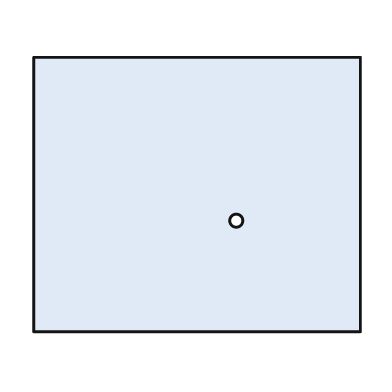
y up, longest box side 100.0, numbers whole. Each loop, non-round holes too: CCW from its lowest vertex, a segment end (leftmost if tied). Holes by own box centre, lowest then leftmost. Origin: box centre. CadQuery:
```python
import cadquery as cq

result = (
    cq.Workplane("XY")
    .moveTo(-50.0, -42.0)
    .lineTo(50.0, -42.0)
    .lineTo(50.0, 42.0)
    .lineTo(-50.0, 42.0)
    .close()
    .moveTo(12.0, -8.0)
    .circle(2.0)
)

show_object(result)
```